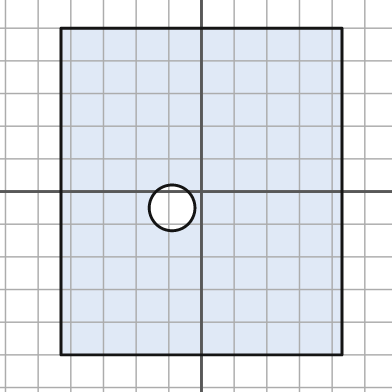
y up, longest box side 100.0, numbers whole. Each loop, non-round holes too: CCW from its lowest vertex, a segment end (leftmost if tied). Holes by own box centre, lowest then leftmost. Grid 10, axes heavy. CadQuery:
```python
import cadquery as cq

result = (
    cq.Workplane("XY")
    .moveTo(-43.0, -50.0)
    .lineTo(43.0, -50.0)
    .lineTo(43.0, 50.0)
    .lineTo(-43.0, 50.0)
    .close()
    .moveTo(-9.0, -5.0)
    .circle(7.0)
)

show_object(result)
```